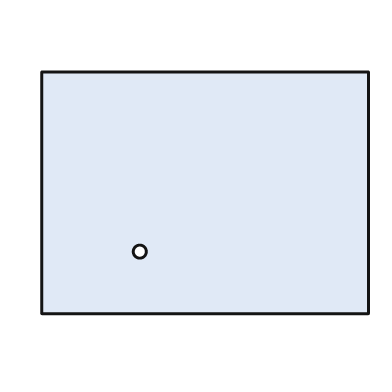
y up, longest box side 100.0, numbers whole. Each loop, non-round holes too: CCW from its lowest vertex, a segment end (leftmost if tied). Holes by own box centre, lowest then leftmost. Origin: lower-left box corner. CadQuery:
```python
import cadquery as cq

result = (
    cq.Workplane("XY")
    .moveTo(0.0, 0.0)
    .lineTo(100.0, 0.0)
    .lineTo(100.0, 74.0)
    .lineTo(0.0, 74.0)
    .close()
    .moveTo(30.0, 19.0)
    .circle(2.0)
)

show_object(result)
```